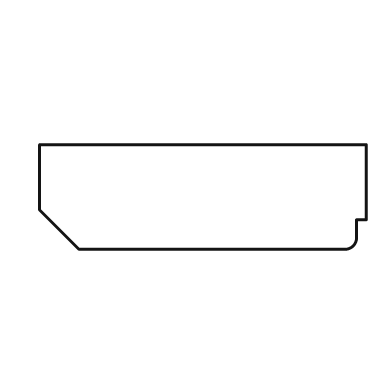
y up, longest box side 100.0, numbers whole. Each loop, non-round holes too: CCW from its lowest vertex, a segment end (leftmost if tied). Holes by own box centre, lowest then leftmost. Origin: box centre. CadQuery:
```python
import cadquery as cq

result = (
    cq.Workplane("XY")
    .moveTo(-38.0, -16.0)
    .lineTo(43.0, -16.0)
    .threePointArc((46.0, -15.0), (47.0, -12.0))
    .lineTo(47.0, -7.0)
    .lineTo(50.0, -7.0)
    .lineTo(50.0, 16.0)
    .lineTo(-50.0, 16.0)
    .lineTo(-50.0, -4.0)
    .close()
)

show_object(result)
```